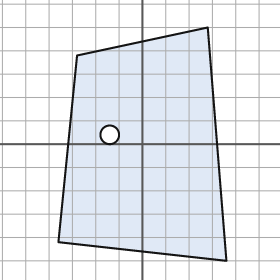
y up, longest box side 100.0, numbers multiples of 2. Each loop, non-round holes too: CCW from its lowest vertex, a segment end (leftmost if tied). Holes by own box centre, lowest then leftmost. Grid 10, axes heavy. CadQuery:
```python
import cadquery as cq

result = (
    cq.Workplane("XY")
    .moveTo(36.0, -50.0)
    .lineTo(28.0, 50.0)
    .lineTo(-28.0, 38.0)
    .lineTo(-36.0, -42.0)
    .close()
    .moveTo(-14.0, 4.0)
    .circle(4.0)
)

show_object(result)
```